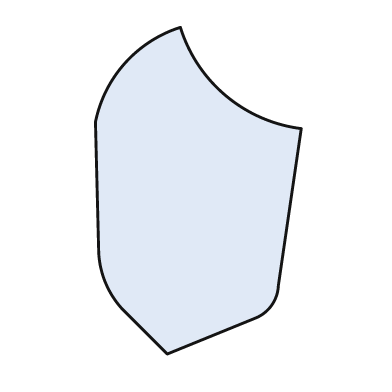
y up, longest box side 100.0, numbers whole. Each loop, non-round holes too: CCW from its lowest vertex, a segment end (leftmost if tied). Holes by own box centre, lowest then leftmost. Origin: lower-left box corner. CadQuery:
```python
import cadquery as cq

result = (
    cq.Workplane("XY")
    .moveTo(22.0, 0.0)
    .lineTo(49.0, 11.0)
    .threePointArc((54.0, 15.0), (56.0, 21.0))
    .lineTo(63.0, 69.0)
    .threePointArc((40.0, 79.0), (26.0, 100.0))
    .threePointArc((9.0, 89.0), (0.0, 71.0))
    .lineTo(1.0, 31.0)
    .threePointArc((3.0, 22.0), (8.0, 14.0))
    .close()
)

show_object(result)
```